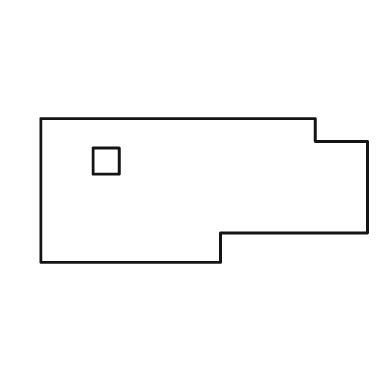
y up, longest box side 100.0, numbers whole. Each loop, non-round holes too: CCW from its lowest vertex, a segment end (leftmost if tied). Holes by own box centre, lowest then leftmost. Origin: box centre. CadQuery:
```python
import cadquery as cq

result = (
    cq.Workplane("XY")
    .moveTo(-50.0, -22.0)
    .lineTo(5.0, -22.0)
    .lineTo(5.0, -13.0)
    .lineTo(50.0, -13.0)
    .lineTo(50.0, 15.0)
    .lineTo(34.0, 15.0)
    .lineTo(34.0, 22.0)
    .lineTo(-50.0, 22.0)
    .close()
    .moveTo(-34.0, 5.0)
    .lineTo(-26.0, 5.0)
    .lineTo(-26.0, 13.0)
    .lineTo(-34.0, 13.0)
    .close()
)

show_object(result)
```